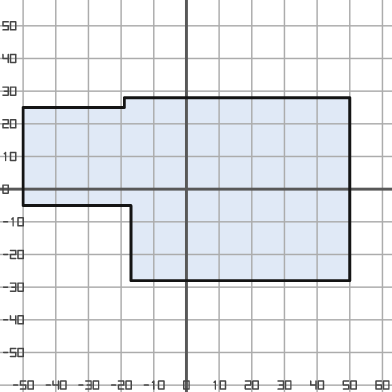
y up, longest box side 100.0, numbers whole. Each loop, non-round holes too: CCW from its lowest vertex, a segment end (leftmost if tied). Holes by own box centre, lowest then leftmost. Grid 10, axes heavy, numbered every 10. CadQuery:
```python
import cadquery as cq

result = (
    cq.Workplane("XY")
    .moveTo(-17.0, -28.0)
    .lineTo(50.0, -28.0)
    .lineTo(50.0, 28.0)
    .lineTo(-19.0, 28.0)
    .lineTo(-19.0, 25.0)
    .lineTo(-50.0, 25.0)
    .lineTo(-50.0, -5.0)
    .lineTo(-17.0, -5.0)
    .close()
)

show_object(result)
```